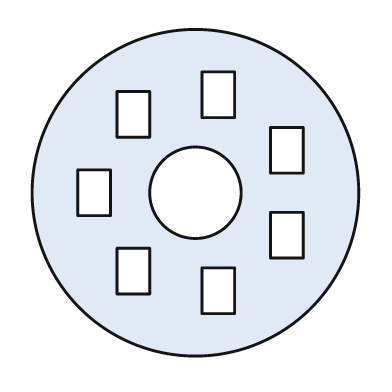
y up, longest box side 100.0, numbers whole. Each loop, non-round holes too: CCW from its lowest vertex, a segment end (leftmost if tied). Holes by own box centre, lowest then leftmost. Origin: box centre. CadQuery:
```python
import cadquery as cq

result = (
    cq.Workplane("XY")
    .moveTo(0.0, 0.0)
    .circle(50.0)
    .moveTo(2.0, -37.0)
    .lineTo(12.0, -37.0)
    .lineTo(12.0, -23.0)
    .lineTo(2.0, -23.0)
    .close()
    .moveTo(-24.0, -31.0)
    .lineTo(-14.0, -31.0)
    .lineTo(-14.0, -17.0)
    .lineTo(-24.0, -17.0)
    .close()
    .moveTo(23.0, -20.0)
    .lineTo(33.0, -20.0)
    .lineTo(33.0, -6.0)
    .lineTo(23.0, -6.0)
    .close()
    .moveTo(-36.0, -7.0)
    .lineTo(-26.0, -7.0)
    .lineTo(-26.0, 7.0)
    .lineTo(-36.0, 7.0)
    .close()
    .moveTo(0.0, 0.0)
    .circle(14.0)
    .moveTo(23.0, 6.0)
    .lineTo(33.0, 6.0)
    .lineTo(33.0, 20.0)
    .lineTo(23.0, 20.0)
    .close()
    .moveTo(-24.0, 17.0)
    .lineTo(-14.0, 17.0)
    .lineTo(-14.0, 31.0)
    .lineTo(-24.0, 31.0)
    .close()
    .moveTo(2.0, 23.0)
    .lineTo(12.0, 23.0)
    .lineTo(12.0, 37.0)
    .lineTo(2.0, 37.0)
    .close()
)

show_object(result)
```